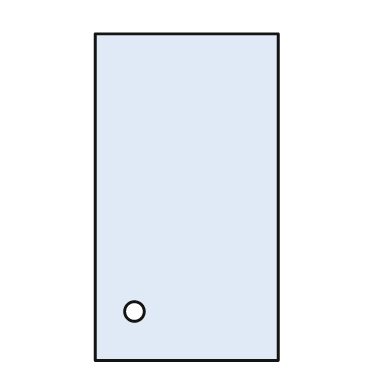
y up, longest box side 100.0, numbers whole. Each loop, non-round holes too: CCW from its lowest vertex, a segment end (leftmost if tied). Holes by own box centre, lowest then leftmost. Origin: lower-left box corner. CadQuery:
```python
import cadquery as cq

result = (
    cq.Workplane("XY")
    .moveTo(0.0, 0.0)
    .lineTo(56.0, 0.0)
    .lineTo(56.0, 100.0)
    .lineTo(0.0, 100.0)
    .close()
    .moveTo(12.0, 15.0)
    .circle(3.0)
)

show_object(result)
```